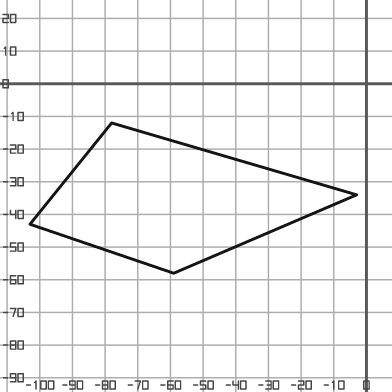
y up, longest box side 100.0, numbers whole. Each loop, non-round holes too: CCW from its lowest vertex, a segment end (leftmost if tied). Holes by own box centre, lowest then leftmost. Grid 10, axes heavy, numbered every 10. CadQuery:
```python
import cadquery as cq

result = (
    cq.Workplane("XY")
    .moveTo(-59.0, -58.0)
    .lineTo(-3.0, -34.0)
    .lineTo(-78.0, -12.0)
    .lineTo(-103.0, -43.0)
    .close()
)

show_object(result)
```